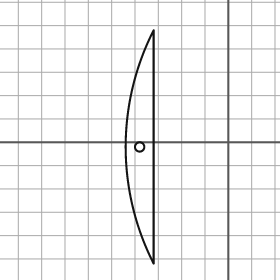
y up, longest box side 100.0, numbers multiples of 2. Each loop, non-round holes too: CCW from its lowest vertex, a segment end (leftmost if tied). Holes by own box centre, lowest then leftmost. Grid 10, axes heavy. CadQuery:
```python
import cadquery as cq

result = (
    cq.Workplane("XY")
    .moveTo(-32.0, -52.0)
    .lineTo(-32.0, 48.0)
    .threePointArc((-44.0, -2.0), (-32.0, -52.0))
    .close()
    .moveTo(-38.0, -2.0)
    .circle(2.0)
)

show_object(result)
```